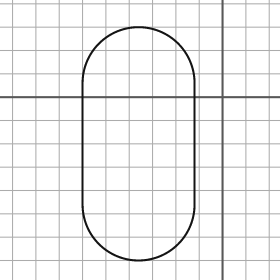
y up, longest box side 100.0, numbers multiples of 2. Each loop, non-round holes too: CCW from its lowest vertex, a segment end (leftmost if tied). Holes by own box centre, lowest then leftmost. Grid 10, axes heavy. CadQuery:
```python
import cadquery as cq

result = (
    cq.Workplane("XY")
    .moveTo(-60.0, -46.0)
    .threePointArc((-36.0, -70.0), (-12.0, -46.0))
    .lineTo(-12.0, 6.0)
    .threePointArc((-36.0, 30.0), (-60.0, 6.0))
    .close()
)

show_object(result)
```